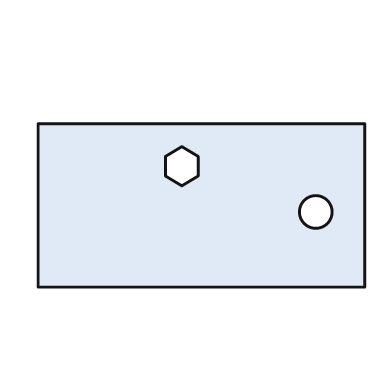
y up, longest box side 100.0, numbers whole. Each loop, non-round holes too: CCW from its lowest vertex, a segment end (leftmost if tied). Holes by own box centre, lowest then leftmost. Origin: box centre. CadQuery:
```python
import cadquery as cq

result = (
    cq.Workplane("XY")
    .moveTo(-50.0, -25.0)
    .lineTo(50.0, -25.0)
    .lineTo(50.0, 25.0)
    .lineTo(-50.0, 25.0)
    .close()
    .moveTo(35.0, -2.0)
    .circle(5.0)
    .moveTo(-6.0, 6.0)
    .lineTo(-1.0, 9.0)
    .lineTo(-1.0, 15.0)
    .lineTo(-6.0, 18.0)
    .lineTo(-11.0, 15.0)
    .lineTo(-11.0, 9.0)
    .close()
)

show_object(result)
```